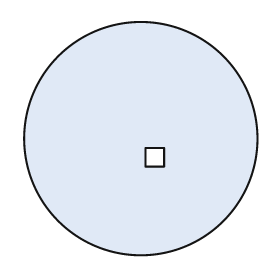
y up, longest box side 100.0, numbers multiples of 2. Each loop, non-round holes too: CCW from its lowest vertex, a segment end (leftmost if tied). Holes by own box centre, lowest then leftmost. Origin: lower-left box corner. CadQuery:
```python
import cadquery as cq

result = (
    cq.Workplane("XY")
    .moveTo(50.0, 50.0)
    .circle(50.0)
    .moveTo(52.0, 38.0)
    .lineTo(60.0, 38.0)
    .lineTo(60.0, 46.0)
    .lineTo(52.0, 46.0)
    .close()
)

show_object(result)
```